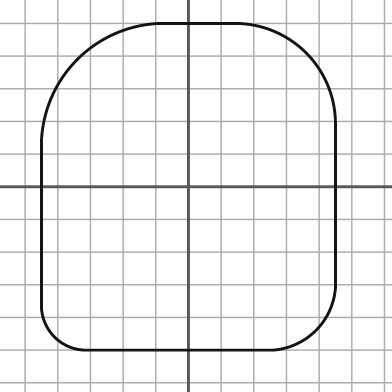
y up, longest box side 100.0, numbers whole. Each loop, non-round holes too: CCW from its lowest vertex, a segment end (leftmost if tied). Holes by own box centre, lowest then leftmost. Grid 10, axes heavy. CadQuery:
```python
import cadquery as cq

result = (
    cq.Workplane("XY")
    .moveTo(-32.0, -50.0)
    .lineTo(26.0, -50.0)
    .threePointArc((39.0, -44.0), (45.0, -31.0))
    .lineTo(45.0, 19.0)
    .threePointArc((36.0, 41.0), (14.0, 50.0))
    .lineTo(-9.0, 50.0)
    .threePointArc((-34.0, 39.0), (-45.0, 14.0))
    .lineTo(-45.0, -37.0)
    .threePointArc((-41.0, -46.0), (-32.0, -50.0))
    .close()
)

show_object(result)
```